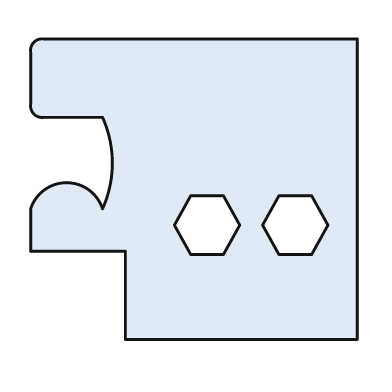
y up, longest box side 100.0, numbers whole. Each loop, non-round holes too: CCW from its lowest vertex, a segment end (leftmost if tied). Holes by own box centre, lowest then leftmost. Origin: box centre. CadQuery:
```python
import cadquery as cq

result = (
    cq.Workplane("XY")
    .moveTo(-21.0, -46.0)
    .lineTo(50.0, -46.0)
    .lineTo(50.0, 46.0)
    .lineTo(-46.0, 46.0)
    .threePointArc((-49.0, 45.0), (-50.0, 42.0))
    .lineTo(-50.0, 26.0)
    .threePointArc((-49.0, 23.0), (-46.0, 22.0))
    .lineTo(-28.0, 22.0)
    .threePointArc((-25.0, 8.0), (-28.0, -6.0))
    .threePointArc((-39.0, 2.0), (-50.0, -6.0))
    .lineTo(-50.0, -19.0)
    .lineTo(-21.0, -19.0)
    .close()
    .moveTo(-1.0, -20.0)
    .lineTo(9.0, -20.0)
    .lineTo(14.0, -11.0)
    .lineTo(9.0, -2.0)
    .lineTo(-1.0, -2.0)
    .lineTo(-6.0, -11.0)
    .close()
    .moveTo(26.0, -20.0)
    .lineTo(36.0, -20.0)
    .lineTo(41.0, -11.0)
    .lineTo(36.0, -2.0)
    .lineTo(26.0, -2.0)
    .lineTo(21.0, -11.0)
    .close()
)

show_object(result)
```